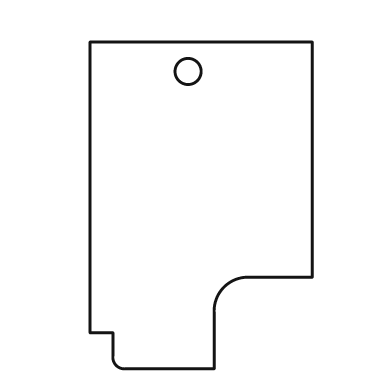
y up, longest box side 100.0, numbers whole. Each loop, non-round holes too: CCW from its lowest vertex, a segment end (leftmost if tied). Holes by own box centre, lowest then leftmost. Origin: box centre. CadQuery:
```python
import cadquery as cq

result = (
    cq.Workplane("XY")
    .moveTo(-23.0, -50.0)
    .lineTo(4.0, -50.0)
    .lineTo(4.0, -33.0)
    .threePointArc((7.0, -25.0), (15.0, -22.0))
    .lineTo(34.0, -22.0)
    .lineTo(34.0, 50.0)
    .lineTo(-34.0, 50.0)
    .lineTo(-34.0, -39.0)
    .lineTo(-27.0, -39.0)
    .lineTo(-27.0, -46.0)
    .threePointArc((-26.0, -49.0), (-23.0, -50.0))
    .close()
    .moveTo(-4.0, 41.0)
    .circle(4.0)
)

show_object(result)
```